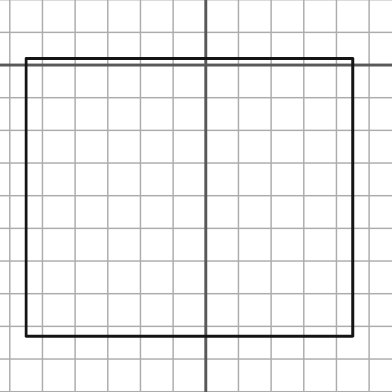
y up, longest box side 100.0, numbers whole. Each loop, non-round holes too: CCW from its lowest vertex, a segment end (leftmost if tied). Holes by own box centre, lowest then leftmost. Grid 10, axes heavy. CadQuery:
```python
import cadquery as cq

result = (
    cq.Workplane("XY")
    .moveTo(-55.0, -83.0)
    .lineTo(45.0, -83.0)
    .lineTo(45.0, 2.0)
    .lineTo(-55.0, 2.0)
    .close()
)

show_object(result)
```